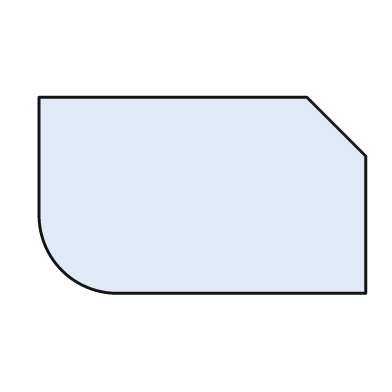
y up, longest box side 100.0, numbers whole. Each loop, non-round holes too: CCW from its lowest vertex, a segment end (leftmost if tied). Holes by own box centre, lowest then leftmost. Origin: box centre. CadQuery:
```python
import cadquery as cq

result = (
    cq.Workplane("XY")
    .moveTo(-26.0, -30.0)
    .lineTo(50.0, -30.0)
    .lineTo(50.0, 12.0)
    .lineTo(32.0, 30.0)
    .lineTo(-50.0, 30.0)
    .lineTo(-50.0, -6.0)
    .threePointArc((-43.0, -23.0), (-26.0, -30.0))
    .close()
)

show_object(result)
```